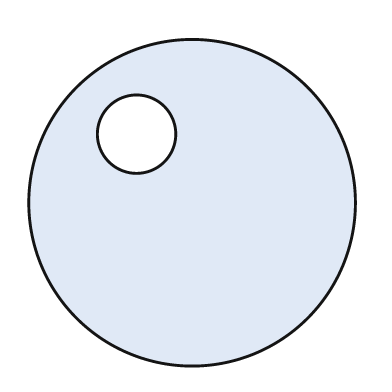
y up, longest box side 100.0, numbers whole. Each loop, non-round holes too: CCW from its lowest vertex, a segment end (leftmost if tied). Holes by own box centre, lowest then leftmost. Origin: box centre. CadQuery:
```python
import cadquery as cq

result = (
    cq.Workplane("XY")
    .moveTo(0.0, 0.0)
    .circle(50.0)
    .moveTo(-17.0, 21.0)
    .circle(12.0)
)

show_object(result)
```